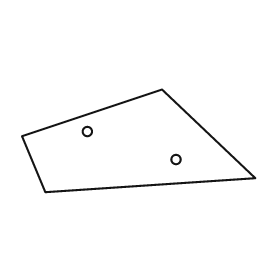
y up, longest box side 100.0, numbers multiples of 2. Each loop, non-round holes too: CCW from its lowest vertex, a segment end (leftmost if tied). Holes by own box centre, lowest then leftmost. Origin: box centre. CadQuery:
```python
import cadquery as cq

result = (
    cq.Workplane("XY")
    .moveTo(-40.0, -22.0)
    .lineTo(50.0, -16.0)
    .lineTo(10.0, 22.0)
    .lineTo(-50.0, 2.0)
    .close()
    .moveTo(16.0, -8.0)
    .circle(2.0)
    .moveTo(-22.0, 4.0)
    .circle(2.0)
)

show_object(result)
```